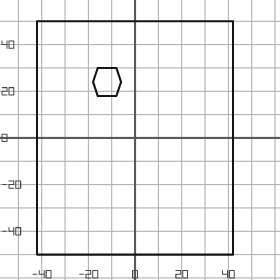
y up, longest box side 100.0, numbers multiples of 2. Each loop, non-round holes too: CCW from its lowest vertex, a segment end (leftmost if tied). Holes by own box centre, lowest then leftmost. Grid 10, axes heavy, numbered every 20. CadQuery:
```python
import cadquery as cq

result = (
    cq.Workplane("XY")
    .moveTo(-42.0, -50.0)
    .lineTo(42.0, -50.0)
    .lineTo(42.0, 50.0)
    .lineTo(-42.0, 50.0)
    .close()
    .moveTo(-16.0, 18.0)
    .lineTo(-8.0, 18.0)
    .lineTo(-6.0, 24.0)
    .lineTo(-8.0, 30.0)
    .lineTo(-16.0, 30.0)
    .lineTo(-18.0, 24.0)
    .close()
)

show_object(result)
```